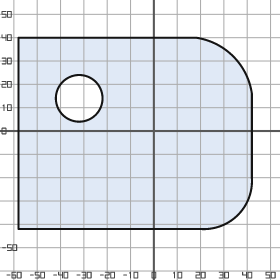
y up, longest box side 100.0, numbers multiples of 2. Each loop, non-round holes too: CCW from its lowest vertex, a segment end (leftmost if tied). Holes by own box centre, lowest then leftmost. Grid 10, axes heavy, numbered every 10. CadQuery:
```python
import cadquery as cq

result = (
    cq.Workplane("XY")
    .moveTo(-58.0, -42.0)
    .lineTo(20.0, -42.0)
    .threePointArc((36.0, -36.0), (42.0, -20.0))
    .lineTo(42.0, 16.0)
    .threePointArc((34.0, 32.0), (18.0, 40.0))
    .lineTo(-58.0, 40.0)
    .close()
    .moveTo(-32.0, 14.0)
    .circle(10.0)
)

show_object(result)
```